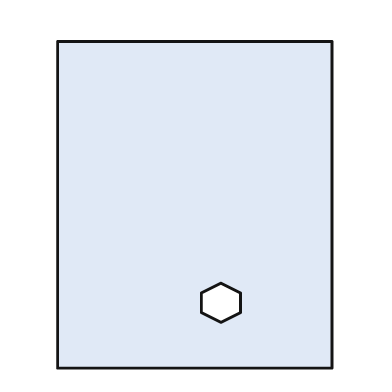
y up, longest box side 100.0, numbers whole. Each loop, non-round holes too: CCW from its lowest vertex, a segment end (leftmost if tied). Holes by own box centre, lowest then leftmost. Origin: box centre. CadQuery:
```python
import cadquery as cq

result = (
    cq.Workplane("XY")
    .moveTo(-42.0, -50.0)
    .lineTo(42.0, -50.0)
    .lineTo(42.0, 50.0)
    .lineTo(-42.0, 50.0)
    .close()
    .moveTo(8.0, -36.0)
    .lineTo(14.0, -33.0)
    .lineTo(14.0, -27.0)
    .lineTo(8.0, -24.0)
    .lineTo(2.0, -27.0)
    .lineTo(2.0, -33.0)
    .close()
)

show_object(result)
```